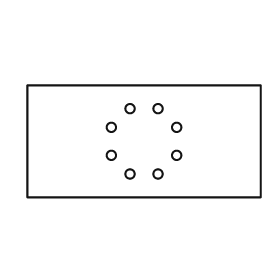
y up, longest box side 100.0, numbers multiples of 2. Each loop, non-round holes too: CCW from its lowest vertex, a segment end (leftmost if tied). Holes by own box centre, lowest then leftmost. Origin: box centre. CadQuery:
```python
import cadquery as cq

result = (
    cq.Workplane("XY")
    .moveTo(-50.0, -24.0)
    .lineTo(50.0, -24.0)
    .lineTo(50.0, 24.0)
    .lineTo(-50.0, 24.0)
    .close()
    .moveTo(-6.0, -14.0)
    .circle(2.0)
    .moveTo(6.0, -14.0)
    .circle(2.0)
    .moveTo(-14.0, -6.0)
    .circle(2.0)
    .moveTo(14.0, -6.0)
    .circle(2.0)
    .moveTo(-14.0, 6.0)
    .circle(2.0)
    .moveTo(14.0, 6.0)
    .circle(2.0)
    .moveTo(-6.0, 14.0)
    .circle(2.0)
    .moveTo(6.0, 14.0)
    .circle(2.0)
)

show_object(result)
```